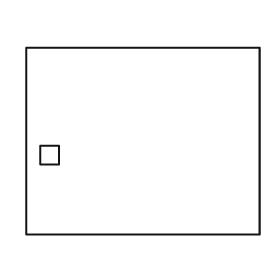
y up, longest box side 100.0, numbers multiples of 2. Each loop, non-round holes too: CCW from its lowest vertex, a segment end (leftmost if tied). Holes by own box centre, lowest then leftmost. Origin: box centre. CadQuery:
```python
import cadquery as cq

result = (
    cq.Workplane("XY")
    .moveTo(-50.0, -40.0)
    .lineTo(50.0, -40.0)
    .lineTo(50.0, 40.0)
    .lineTo(-50.0, 40.0)
    .close()
    .moveTo(-44.0, -10.0)
    .lineTo(-36.0, -10.0)
    .lineTo(-36.0, -2.0)
    .lineTo(-44.0, -2.0)
    .close()
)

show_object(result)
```